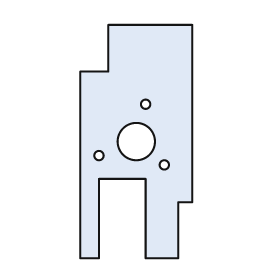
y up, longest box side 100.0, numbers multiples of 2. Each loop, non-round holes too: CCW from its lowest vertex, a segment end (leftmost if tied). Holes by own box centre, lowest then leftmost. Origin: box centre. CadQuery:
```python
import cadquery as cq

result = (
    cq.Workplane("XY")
    .moveTo(-24.0, -50.0)
    .lineTo(-16.0, -50.0)
    .lineTo(-16.0, -16.0)
    .lineTo(4.0, -16.0)
    .lineTo(4.0, -50.0)
    .lineTo(18.0, -50.0)
    .lineTo(18.0, -26.0)
    .lineTo(24.0, -26.0)
    .lineTo(24.0, 50.0)
    .lineTo(-12.0, 50.0)
    .lineTo(-12.0, 30.0)
    .lineTo(-24.0, 30.0)
    .close()
    .moveTo(12.0, -10.0)
    .circle(2.0)
    .moveTo(-16.0, -6.0)
    .circle(2.0)
    .moveTo(0.0, 0.0)
    .circle(8.0)
    .moveTo(4.0, 16.0)
    .circle(2.0)
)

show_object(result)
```